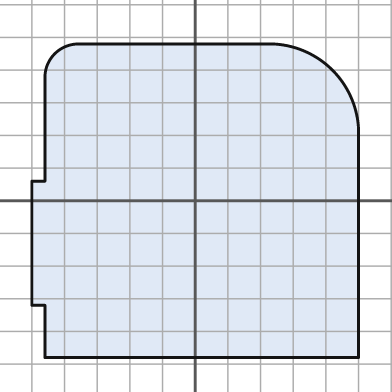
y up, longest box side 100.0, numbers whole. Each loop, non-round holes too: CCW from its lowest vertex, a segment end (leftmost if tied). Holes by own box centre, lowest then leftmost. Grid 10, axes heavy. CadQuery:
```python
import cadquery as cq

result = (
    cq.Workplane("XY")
    .moveTo(-46.0, -48.0)
    .lineTo(50.0, -48.0)
    .lineTo(50.0, 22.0)
    .threePointArc((42.0, 40.0), (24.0, 48.0))
    .lineTo(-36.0, 48.0)
    .threePointArc((-43.0, 45.0), (-46.0, 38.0))
    .lineTo(-46.0, 6.0)
    .lineTo(-50.0, 6.0)
    .lineTo(-50.0, -32.0)
    .lineTo(-46.0, -32.0)
    .close()
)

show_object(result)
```